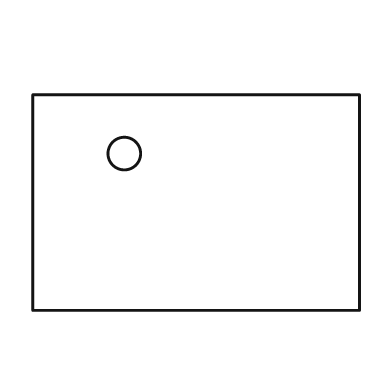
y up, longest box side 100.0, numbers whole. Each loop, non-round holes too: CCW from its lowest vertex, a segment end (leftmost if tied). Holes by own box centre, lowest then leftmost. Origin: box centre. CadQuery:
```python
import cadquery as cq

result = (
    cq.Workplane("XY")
    .moveTo(-50.0, -33.0)
    .lineTo(50.0, -33.0)
    .lineTo(50.0, 33.0)
    .lineTo(-50.0, 33.0)
    .close()
    .moveTo(-22.0, 15.0)
    .circle(5.0)
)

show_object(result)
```